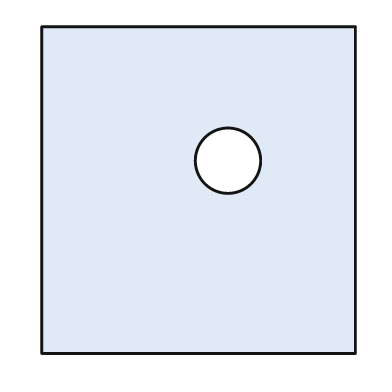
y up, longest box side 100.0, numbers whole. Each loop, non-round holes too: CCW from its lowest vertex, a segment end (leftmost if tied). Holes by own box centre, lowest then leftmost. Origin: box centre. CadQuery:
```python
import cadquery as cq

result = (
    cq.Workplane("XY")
    .moveTo(-48.0, -50.0)
    .lineTo(48.0, -50.0)
    .lineTo(48.0, 50.0)
    .lineTo(-48.0, 50.0)
    .close()
    .moveTo(9.0, 9.0)
    .circle(10.0)
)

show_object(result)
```